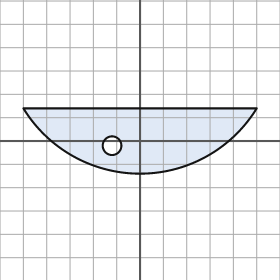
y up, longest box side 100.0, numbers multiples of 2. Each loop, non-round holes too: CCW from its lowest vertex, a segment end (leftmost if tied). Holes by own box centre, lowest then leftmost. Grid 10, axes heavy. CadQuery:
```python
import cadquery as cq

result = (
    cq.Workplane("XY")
    .moveTo(-50.0, 14.0)
    .threePointArc((0.0, -14.0), (50.0, 14.0))
    .close()
    .moveTo(-12.0, -2.0)
    .circle(4.0)
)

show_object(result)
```